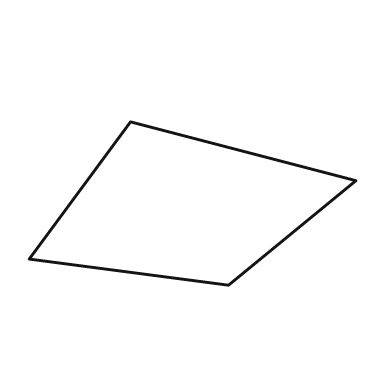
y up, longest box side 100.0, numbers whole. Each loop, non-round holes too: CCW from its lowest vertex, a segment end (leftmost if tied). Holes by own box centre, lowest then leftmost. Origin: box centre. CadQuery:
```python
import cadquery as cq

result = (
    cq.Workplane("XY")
    .moveTo(11.0, -25.0)
    .lineTo(50.0, 7.0)
    .lineTo(-19.0, 25.0)
    .lineTo(-50.0, -17.0)
    .close()
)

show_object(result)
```